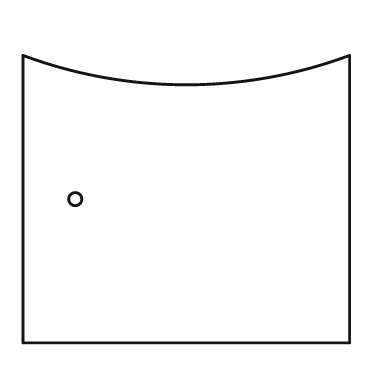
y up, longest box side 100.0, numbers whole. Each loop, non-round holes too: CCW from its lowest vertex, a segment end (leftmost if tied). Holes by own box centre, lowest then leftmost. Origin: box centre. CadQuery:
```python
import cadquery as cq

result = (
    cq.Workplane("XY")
    .moveTo(-50.0, -44.0)
    .lineTo(50.0, -44.0)
    .lineTo(50.0, 44.0)
    .threePointArc((0.0, 35.0), (-50.0, 44.0))
    .close()
    .moveTo(-34.0, 0.0)
    .circle(2.0)
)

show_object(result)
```